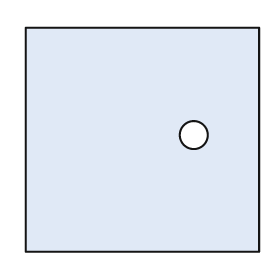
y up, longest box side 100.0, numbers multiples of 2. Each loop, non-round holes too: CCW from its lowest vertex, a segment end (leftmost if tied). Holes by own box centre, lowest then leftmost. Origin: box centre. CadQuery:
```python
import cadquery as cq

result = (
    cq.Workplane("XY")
    .moveTo(-50.0, -48.0)
    .lineTo(50.0, -48.0)
    .lineTo(50.0, 48.0)
    .lineTo(-50.0, 48.0)
    .close()
    .moveTo(22.0, 2.0)
    .circle(6.0)
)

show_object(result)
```